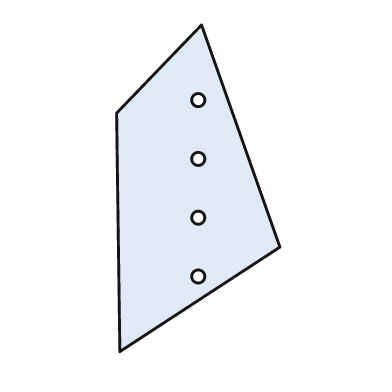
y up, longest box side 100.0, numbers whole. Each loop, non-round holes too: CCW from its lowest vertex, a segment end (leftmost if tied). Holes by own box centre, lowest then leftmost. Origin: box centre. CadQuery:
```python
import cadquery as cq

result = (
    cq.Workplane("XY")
    .moveTo(-24.0, -50.0)
    .lineTo(25.0, -18.0)
    .lineTo(1.0, 50.0)
    .lineTo(-25.0, 23.0)
    .close()
    .moveTo(0.0, -27.0)
    .circle(2.0)
    .moveTo(0.0, -9.0)
    .circle(2.0)
    .moveTo(0.0, 9.0)
    .circle(2.0)
    .moveTo(0.0, 27.0)
    .circle(2.0)
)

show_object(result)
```